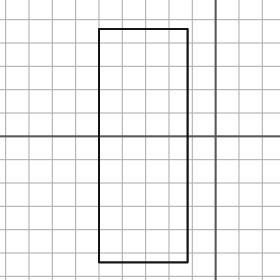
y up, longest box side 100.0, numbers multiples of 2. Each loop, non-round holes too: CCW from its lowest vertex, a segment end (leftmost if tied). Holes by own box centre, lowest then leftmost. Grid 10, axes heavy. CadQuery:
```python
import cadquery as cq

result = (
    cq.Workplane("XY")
    .moveTo(-50.0, -54.0)
    .lineTo(-12.0, -54.0)
    .lineTo(-12.0, 46.0)
    .lineTo(-50.0, 46.0)
    .close()
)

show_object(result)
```